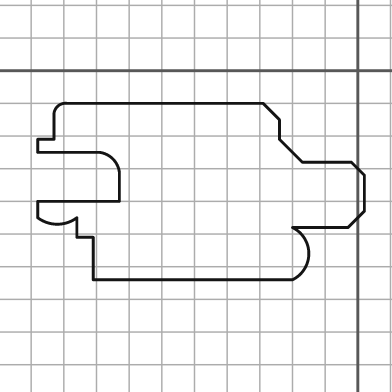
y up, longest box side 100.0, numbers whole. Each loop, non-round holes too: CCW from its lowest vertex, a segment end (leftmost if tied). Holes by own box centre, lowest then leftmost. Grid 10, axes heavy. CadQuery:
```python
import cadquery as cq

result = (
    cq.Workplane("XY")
    .moveTo(-81.0, -64.0)
    .lineTo(-20.0, -64.0)
    .threePointArc((-15.0, -56.0), (-20.0, -48.0))
    .lineTo(-3.0, -48.0)
    .lineTo(2.0, -43.0)
    .lineTo(2.0, -32.0)
    .lineTo(-2.0, -28.0)
    .lineTo(-17.0, -28.0)
    .lineTo(-24.0, -21.0)
    .lineTo(-24.0, -15.0)
    .lineTo(-29.0, -10.0)
    .lineTo(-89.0, -10.0)
    .threePointArc((-92.0, -11.0), (-93.0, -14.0))
    .lineTo(-93.0, -21.0)
    .lineTo(-98.0, -21.0)
    .lineTo(-98.0, -25.0)
    .lineTo(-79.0, -25.0)
    .threePointArc((-75.0, -27.0), (-73.0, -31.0))
    .lineTo(-73.0, -40.0)
    .lineTo(-98.0, -40.0)
    .lineTo(-98.0, -45.0)
    .threePointArc((-92.0, -47.0), (-86.0, -45.0))
    .lineTo(-86.0, -51.0)
    .lineTo(-81.0, -51.0)
    .close()
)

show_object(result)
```